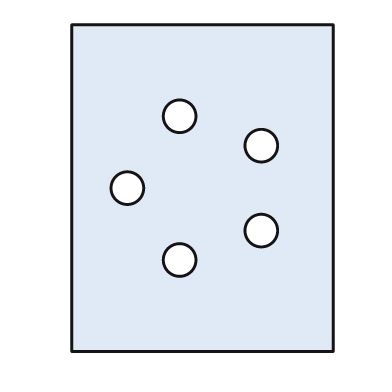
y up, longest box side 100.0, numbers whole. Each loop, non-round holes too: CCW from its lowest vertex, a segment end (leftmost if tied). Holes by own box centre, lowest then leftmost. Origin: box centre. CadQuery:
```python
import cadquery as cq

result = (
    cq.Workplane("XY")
    .moveTo(-40.0, -50.0)
    .lineTo(40.0, -50.0)
    .lineTo(40.0, 50.0)
    .lineTo(-40.0, 50.0)
    .close()
    .moveTo(-7.0, -22.0)
    .circle(5.0)
    .moveTo(18.0, -13.0)
    .circle(5.0)
    .moveTo(-23.0, 0.0)
    .circle(5.0)
    .moveTo(18.0, 13.0)
    .circle(5.0)
    .moveTo(-7.0, 22.0)
    .circle(5.0)
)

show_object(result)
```